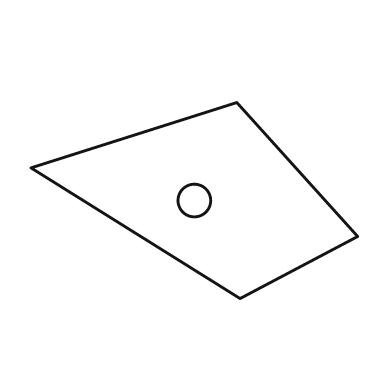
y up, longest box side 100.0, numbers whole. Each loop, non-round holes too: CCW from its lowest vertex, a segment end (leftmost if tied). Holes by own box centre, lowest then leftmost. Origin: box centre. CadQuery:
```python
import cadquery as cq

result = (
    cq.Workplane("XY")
    .moveTo(14.0, -30.0)
    .lineTo(50.0, -11.0)
    .lineTo(13.0, 30.0)
    .lineTo(-50.0, 10.0)
    .close()
    .moveTo(0.0, 0.0)
    .circle(5.0)
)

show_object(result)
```